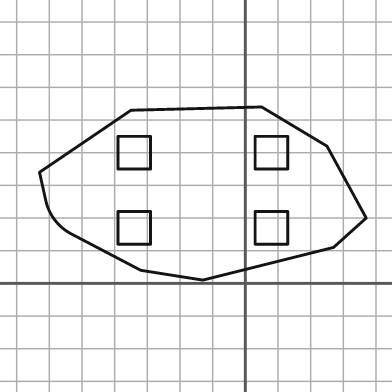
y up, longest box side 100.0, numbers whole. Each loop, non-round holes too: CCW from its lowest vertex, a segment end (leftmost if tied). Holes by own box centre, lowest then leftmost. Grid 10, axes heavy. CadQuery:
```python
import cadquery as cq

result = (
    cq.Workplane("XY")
    .moveTo(-13.0, 1.0)
    .lineTo(27.0, 11.0)
    .lineTo(37.0, 20.0)
    .lineTo(25.0, 42.0)
    .lineTo(5.0, 54.0)
    .lineTo(-35.0, 53.0)
    .lineTo(-63.0, 34.0)
    .lineTo(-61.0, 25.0)
    .threePointArc((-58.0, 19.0), (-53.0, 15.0))
    .lineTo(-32.0, 4.0)
    .close()
    .moveTo(-39.0, 12.0)
    .lineTo(-29.0, 12.0)
    .lineTo(-29.0, 22.0)
    .lineTo(-39.0, 22.0)
    .close()
    .moveTo(3.0, 12.0)
    .lineTo(13.0, 12.0)
    .lineTo(13.0, 22.0)
    .lineTo(3.0, 22.0)
    .close()
    .moveTo(-39.0, 35.0)
    .lineTo(-29.0, 35.0)
    .lineTo(-29.0, 45.0)
    .lineTo(-39.0, 45.0)
    .close()
    .moveTo(3.0, 35.0)
    .lineTo(13.0, 35.0)
    .lineTo(13.0, 45.0)
    .lineTo(3.0, 45.0)
    .close()
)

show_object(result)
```